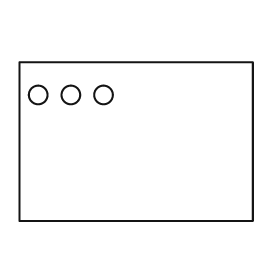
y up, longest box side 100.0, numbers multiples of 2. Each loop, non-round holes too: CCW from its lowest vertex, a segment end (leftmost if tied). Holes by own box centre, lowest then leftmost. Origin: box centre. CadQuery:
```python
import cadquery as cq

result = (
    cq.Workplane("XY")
    .moveTo(-50.0, -34.0)
    .lineTo(50.0, -34.0)
    .lineTo(50.0, 34.0)
    .lineTo(-50.0, 34.0)
    .close()
    .moveTo(-42.0, 20.0)
    .circle(4.0)
    .moveTo(-28.0, 20.0)
    .circle(4.0)
    .moveTo(-14.0, 20.0)
    .circle(4.0)
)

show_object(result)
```